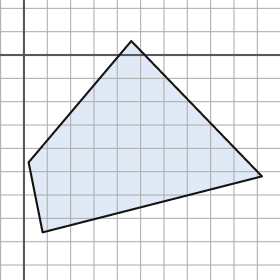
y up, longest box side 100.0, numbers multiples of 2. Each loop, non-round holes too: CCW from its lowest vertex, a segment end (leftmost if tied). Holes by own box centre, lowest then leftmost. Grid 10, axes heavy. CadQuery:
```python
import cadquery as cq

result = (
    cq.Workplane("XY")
    .moveTo(8.0, -76.0)
    .lineTo(102.0, -52.0)
    .lineTo(46.0, 6.0)
    .lineTo(2.0, -46.0)
    .close()
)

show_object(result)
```